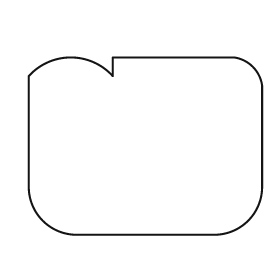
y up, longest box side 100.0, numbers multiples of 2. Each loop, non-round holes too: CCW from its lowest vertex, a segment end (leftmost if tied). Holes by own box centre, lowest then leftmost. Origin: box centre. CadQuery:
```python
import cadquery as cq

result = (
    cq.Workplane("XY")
    .moveTo(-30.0, -38.0)
    .lineTo(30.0, -38.0)
    .threePointArc((44.0, -32.0), (50.0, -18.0))
    .lineTo(50.0, 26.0)
    .threePointArc((46.0, 34.0), (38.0, 38.0))
    .lineTo(-14.0, 38.0)
    .lineTo(-14.0, 30.0)
    .threePointArc((-32.0, 38.0), (-50.0, 30.0))
    .lineTo(-50.0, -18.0)
    .threePointArc((-44.0, -32.0), (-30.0, -38.0))
    .close()
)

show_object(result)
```